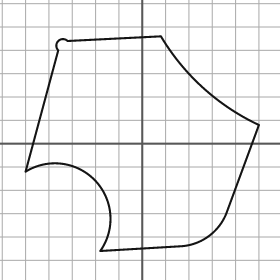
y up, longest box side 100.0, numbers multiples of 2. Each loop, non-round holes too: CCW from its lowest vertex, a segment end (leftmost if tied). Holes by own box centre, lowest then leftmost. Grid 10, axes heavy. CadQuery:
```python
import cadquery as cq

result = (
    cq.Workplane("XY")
    .moveTo(-18.0, -46.0)
    .lineTo(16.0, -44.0)
    .threePointArc((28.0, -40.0), (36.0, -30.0))
    .lineTo(50.0, 8.0)
    .threePointArc((26.0, 24.0), (8.0, 46.0))
    .lineTo(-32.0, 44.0)
    .threePointArc((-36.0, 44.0), (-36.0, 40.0))
    .lineTo(-50.0, -12.0)
    .threePointArc((-20.0, -16.0), (-18.0, -46.0))
    .close()
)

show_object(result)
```